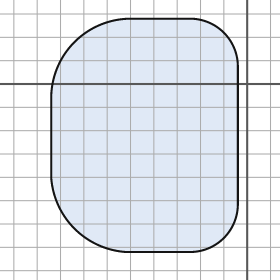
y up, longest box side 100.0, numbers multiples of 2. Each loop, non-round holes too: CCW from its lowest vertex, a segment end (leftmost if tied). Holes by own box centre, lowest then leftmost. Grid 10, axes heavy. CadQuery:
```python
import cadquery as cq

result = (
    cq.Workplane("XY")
    .moveTo(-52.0, -72.0)
    .lineTo(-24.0, -72.0)
    .threePointArc((-10.0, -66.0), (-4.0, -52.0))
    .lineTo(-4.0, 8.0)
    .threePointArc((-10.0, 22.0), (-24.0, 28.0))
    .lineTo(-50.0, 28.0)
    .threePointArc((-74.0, 18.0), (-84.0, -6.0))
    .lineTo(-84.0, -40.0)
    .threePointArc((-74.0, -62.0), (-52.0, -72.0))
    .close()
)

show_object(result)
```